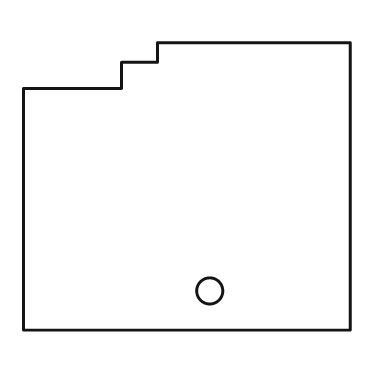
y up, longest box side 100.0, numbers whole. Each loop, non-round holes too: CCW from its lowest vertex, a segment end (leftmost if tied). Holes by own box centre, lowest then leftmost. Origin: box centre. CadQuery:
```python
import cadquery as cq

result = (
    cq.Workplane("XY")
    .moveTo(-50.0, -44.0)
    .lineTo(50.0, -44.0)
    .lineTo(50.0, 44.0)
    .lineTo(-9.0, 44.0)
    .lineTo(-9.0, 38.0)
    .lineTo(-20.0, 38.0)
    .lineTo(-20.0, 30.0)
    .lineTo(-50.0, 30.0)
    .close()
    .moveTo(7.0, -32.0)
    .circle(4.0)
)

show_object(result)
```